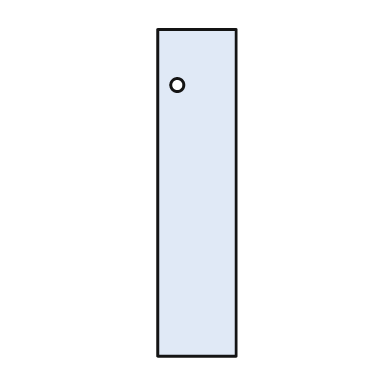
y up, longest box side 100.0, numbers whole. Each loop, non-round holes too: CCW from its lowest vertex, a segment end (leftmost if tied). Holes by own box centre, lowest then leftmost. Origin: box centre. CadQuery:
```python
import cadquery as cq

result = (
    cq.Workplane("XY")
    .moveTo(-12.0, -50.0)
    .lineTo(12.0, -50.0)
    .lineTo(12.0, 50.0)
    .lineTo(-12.0, 50.0)
    .close()
    .moveTo(-6.0, 33.0)
    .circle(2.0)
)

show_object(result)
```